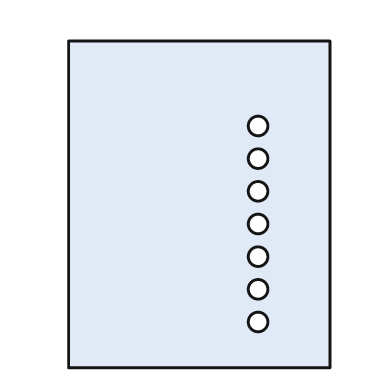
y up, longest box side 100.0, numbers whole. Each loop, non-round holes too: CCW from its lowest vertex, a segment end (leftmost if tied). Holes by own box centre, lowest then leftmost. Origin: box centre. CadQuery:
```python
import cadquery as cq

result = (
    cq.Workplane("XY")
    .moveTo(-40.0, -50.0)
    .lineTo(40.0, -50.0)
    .lineTo(40.0, 50.0)
    .lineTo(-40.0, 50.0)
    .close()
    .moveTo(18.0, -36.0)
    .circle(3.0)
    .moveTo(18.0, -26.0)
    .circle(3.0)
    .moveTo(18.0, -16.0)
    .circle(3.0)
    .moveTo(18.0, -6.0)
    .circle(3.0)
    .moveTo(18.0, 4.0)
    .circle(3.0)
    .moveTo(18.0, 14.0)
    .circle(3.0)
    .moveTo(18.0, 24.0)
    .circle(3.0)
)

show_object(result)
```